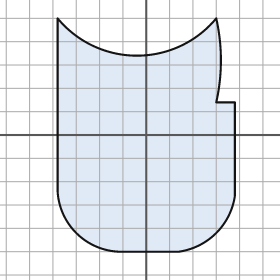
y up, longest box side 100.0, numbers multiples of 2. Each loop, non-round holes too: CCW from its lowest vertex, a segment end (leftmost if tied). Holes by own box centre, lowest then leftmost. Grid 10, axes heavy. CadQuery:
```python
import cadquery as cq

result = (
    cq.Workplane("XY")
    .moveTo(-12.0, -50.0)
    .lineTo(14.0, -50.0)
    .threePointArc((30.0, -42.0), (38.0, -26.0))
    .lineTo(38.0, 14.0)
    .lineTo(30.0, 14.0)
    .threePointArc((32.0, 32.0), (30.0, 50.0))
    .threePointArc((-4.0, 34.0), (-38.0, 50.0))
    .lineTo(-38.0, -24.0)
    .threePointArc((-30.0, -42.0), (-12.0, -50.0))
    .close()
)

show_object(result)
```